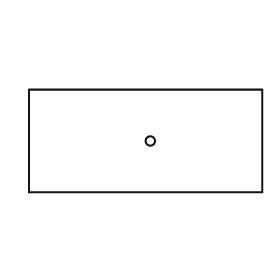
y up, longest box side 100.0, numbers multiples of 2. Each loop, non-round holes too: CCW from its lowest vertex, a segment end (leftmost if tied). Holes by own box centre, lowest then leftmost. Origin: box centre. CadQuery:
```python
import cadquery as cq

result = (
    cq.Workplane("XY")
    .moveTo(-50.0, -22.0)
    .lineTo(50.0, -22.0)
    .lineTo(50.0, 22.0)
    .lineTo(-50.0, 22.0)
    .close()
    .moveTo(2.0, 0.0)
    .circle(2.0)
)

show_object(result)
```